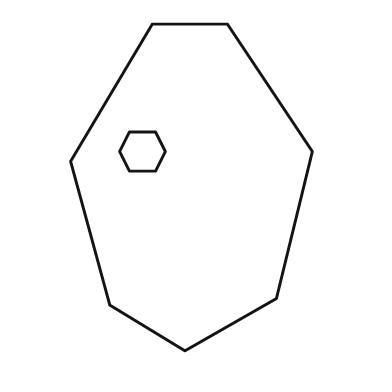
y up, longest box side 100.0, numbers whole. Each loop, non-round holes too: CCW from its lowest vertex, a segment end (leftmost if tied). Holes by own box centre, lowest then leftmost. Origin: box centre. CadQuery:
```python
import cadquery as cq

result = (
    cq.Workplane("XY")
    .moveTo(-2.0, -50.0)
    .lineTo(26.0, -34.0)
    .lineTo(37.0, 11.0)
    .lineTo(11.0, 50.0)
    .lineTo(-12.0, 50.0)
    .lineTo(-37.0, 8.0)
    .lineTo(-25.0, -36.0)
    .close()
    .moveTo(-19.0, 5.0)
    .lineTo(-11.0, 5.0)
    .lineTo(-8.0, 11.0)
    .lineTo(-11.0, 17.0)
    .lineTo(-19.0, 17.0)
    .lineTo(-22.0, 11.0)
    .close()
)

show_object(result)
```